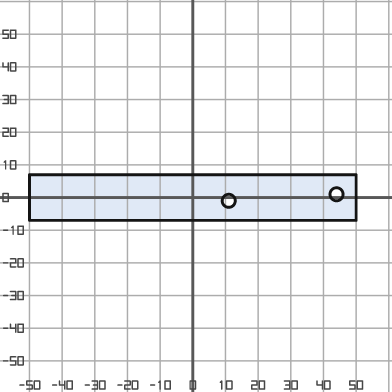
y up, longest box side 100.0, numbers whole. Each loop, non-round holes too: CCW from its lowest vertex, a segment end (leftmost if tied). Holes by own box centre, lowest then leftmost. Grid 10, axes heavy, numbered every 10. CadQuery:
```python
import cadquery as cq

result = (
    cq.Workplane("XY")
    .moveTo(-50.0, -7.0)
    .lineTo(50.0, -7.0)
    .lineTo(50.0, 7.0)
    .lineTo(-50.0, 7.0)
    .close()
    .moveTo(11.0, -1.0)
    .circle(2.0)
    .moveTo(44.0, 1.0)
    .circle(2.0)
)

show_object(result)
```